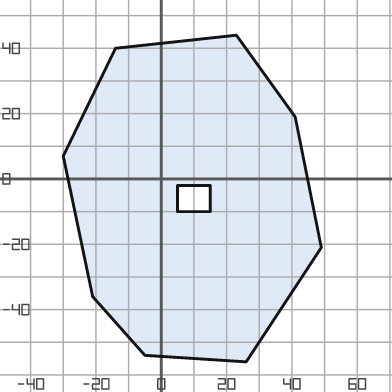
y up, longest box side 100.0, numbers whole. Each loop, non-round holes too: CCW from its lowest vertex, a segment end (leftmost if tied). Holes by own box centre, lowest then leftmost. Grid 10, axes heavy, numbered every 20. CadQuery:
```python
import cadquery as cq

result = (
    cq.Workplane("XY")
    .moveTo(26.0, -56.0)
    .lineTo(49.0, -21.0)
    .lineTo(41.0, 19.0)
    .lineTo(23.0, 44.0)
    .lineTo(-14.0, 40.0)
    .lineTo(-30.0, 7.0)
    .lineTo(-21.0, -36.0)
    .lineTo(-5.0, -54.0)
    .close()
    .moveTo(5.0, -10.0)
    .lineTo(15.0, -10.0)
    .lineTo(15.0, -2.0)
    .lineTo(5.0, -2.0)
    .close()
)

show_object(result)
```